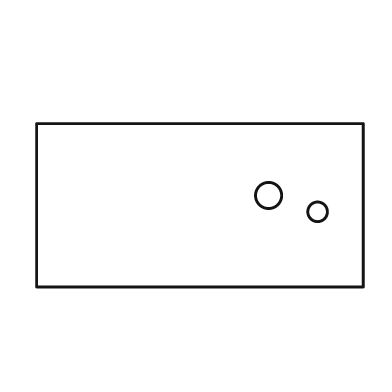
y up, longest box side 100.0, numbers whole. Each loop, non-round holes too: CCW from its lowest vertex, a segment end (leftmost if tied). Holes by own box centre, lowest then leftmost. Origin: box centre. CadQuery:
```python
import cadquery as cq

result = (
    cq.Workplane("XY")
    .moveTo(-50.0, -25.0)
    .lineTo(50.0, -25.0)
    .lineTo(50.0, 25.0)
    .lineTo(-50.0, 25.0)
    .close()
    .moveTo(36.0, -2.0)
    .circle(3.0)
    .moveTo(21.0, 3.0)
    .circle(4.0)
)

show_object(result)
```